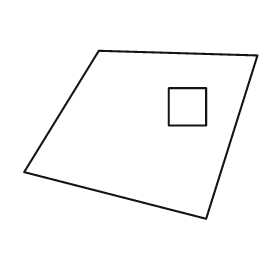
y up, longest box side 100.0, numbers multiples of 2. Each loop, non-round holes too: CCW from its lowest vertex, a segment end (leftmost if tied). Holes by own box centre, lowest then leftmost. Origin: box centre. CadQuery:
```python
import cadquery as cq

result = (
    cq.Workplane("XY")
    .moveTo(28.0, -36.0)
    .lineTo(50.0, 34.0)
    .lineTo(-18.0, 36.0)
    .lineTo(-50.0, -16.0)
    .close()
    .moveTo(12.0, 4.0)
    .lineTo(28.0, 4.0)
    .lineTo(28.0, 20.0)
    .lineTo(12.0, 20.0)
    .close()
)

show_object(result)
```